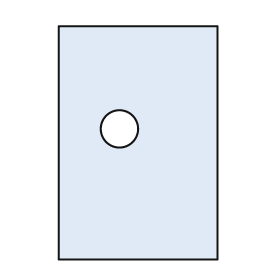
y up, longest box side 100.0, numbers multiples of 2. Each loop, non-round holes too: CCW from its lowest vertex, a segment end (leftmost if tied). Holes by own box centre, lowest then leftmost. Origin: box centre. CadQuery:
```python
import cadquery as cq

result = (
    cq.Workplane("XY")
    .moveTo(-34.0, -50.0)
    .lineTo(34.0, -50.0)
    .lineTo(34.0, 50.0)
    .lineTo(-34.0, 50.0)
    .close()
    .moveTo(-8.0, 6.0)
    .circle(8.0)
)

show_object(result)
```